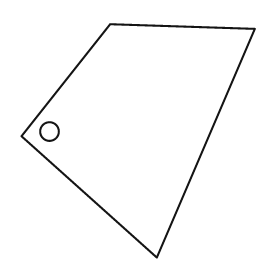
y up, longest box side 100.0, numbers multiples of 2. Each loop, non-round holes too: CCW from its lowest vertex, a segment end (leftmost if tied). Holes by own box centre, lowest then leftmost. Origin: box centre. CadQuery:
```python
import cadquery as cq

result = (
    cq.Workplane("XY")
    .moveTo(8.0, -50.0)
    .lineTo(50.0, 48.0)
    .lineTo(-12.0, 50.0)
    .lineTo(-50.0, 2.0)
    .close()
    .moveTo(-38.0, 4.0)
    .circle(4.0)
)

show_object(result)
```